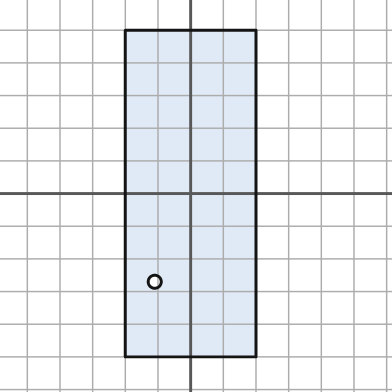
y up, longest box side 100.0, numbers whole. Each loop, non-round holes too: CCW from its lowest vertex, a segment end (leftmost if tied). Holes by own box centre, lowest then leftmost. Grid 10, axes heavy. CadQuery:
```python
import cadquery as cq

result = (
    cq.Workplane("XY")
    .moveTo(-20.0, -50.0)
    .lineTo(20.0, -50.0)
    .lineTo(20.0, 50.0)
    .lineTo(-20.0, 50.0)
    .close()
    .moveTo(-11.0, -27.0)
    .circle(2.0)
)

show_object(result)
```